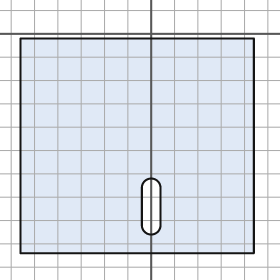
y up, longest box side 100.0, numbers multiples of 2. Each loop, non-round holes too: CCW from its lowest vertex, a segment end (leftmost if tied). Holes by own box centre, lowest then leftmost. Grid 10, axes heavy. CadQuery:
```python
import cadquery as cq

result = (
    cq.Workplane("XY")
    .moveTo(-56.0, -94.0)
    .lineTo(44.0, -94.0)
    .lineTo(44.0, -2.0)
    .lineTo(-56.0, -2.0)
    .close()
    .moveTo(-4.0, -82.0)
    .threePointArc((0.0, -86.0), (4.0, -82.0))
    .lineTo(4.0, -66.0)
    .threePointArc((0.0, -62.0), (-4.0, -66.0))
    .close()
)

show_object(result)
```